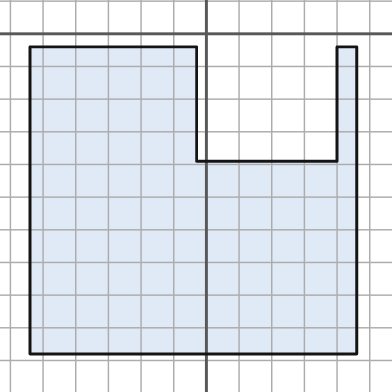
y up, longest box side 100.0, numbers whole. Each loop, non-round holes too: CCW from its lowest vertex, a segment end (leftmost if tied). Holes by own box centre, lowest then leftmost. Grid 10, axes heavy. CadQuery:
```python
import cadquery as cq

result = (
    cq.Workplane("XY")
    .moveTo(-54.0, -98.0)
    .lineTo(46.0, -98.0)
    .lineTo(46.0, -4.0)
    .lineTo(40.0, -4.0)
    .lineTo(40.0, -39.0)
    .lineTo(-3.0, -39.0)
    .lineTo(-3.0, -4.0)
    .lineTo(-54.0, -4.0)
    .close()
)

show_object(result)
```